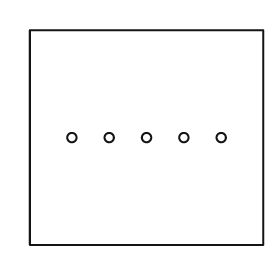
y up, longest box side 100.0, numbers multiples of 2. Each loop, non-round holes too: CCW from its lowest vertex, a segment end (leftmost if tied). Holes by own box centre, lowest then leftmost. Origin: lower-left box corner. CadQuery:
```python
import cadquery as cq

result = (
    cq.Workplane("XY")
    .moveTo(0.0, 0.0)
    .lineTo(100.0, 0.0)
    .lineTo(100.0, 92.0)
    .lineTo(0.0, 92.0)
    .close()
    .moveTo(18.0, 46.0)
    .circle(2.0)
    .moveTo(34.0, 46.0)
    .circle(2.0)
    .moveTo(50.0, 46.0)
    .circle(2.0)
    .moveTo(66.0, 46.0)
    .circle(2.0)
    .moveTo(82.0, 46.0)
    .circle(2.0)
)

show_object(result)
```